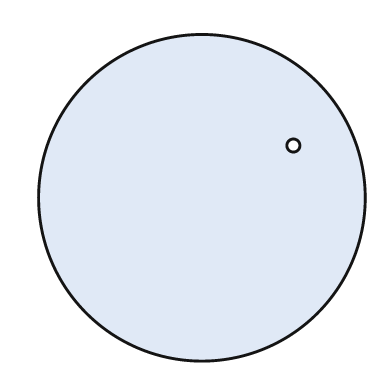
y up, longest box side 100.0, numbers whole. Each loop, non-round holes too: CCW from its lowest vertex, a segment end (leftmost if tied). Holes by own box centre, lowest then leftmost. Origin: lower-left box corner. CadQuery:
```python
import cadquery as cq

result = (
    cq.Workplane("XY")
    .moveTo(50.0, 50.0)
    .circle(50.0)
    .moveTo(78.0, 66.0)
    .circle(2.0)
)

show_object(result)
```